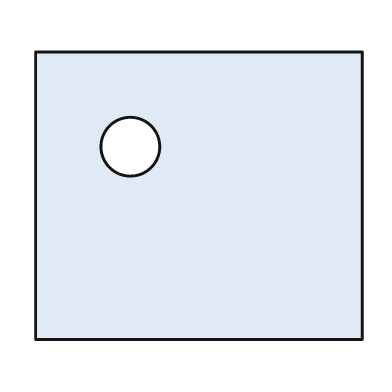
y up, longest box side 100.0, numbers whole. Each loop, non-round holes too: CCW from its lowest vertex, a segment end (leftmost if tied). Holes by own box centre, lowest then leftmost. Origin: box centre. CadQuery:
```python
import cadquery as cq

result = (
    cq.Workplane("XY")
    .moveTo(-50.0, -44.0)
    .lineTo(50.0, -44.0)
    .lineTo(50.0, 44.0)
    .lineTo(-50.0, 44.0)
    .close()
    .moveTo(-21.0, 15.0)
    .circle(9.0)
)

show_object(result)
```